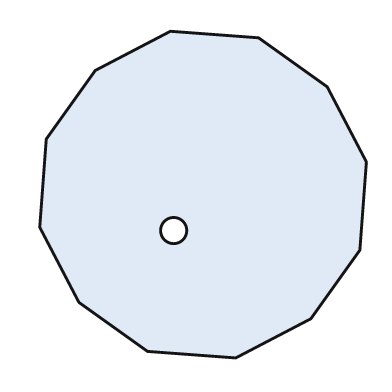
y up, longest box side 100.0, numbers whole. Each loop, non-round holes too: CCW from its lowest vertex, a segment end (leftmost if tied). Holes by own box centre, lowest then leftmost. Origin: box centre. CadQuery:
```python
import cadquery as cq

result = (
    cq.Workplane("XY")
    .moveTo(10.0, -50.0)
    .lineTo(33.0, -38.0)
    .lineTo(48.0, -17.0)
    .lineTo(50.0, 10.0)
    .lineTo(38.0, 33.0)
    .lineTo(17.0, 48.0)
    .lineTo(-10.0, 50.0)
    .lineTo(-33.0, 38.0)
    .lineTo(-48.0, 17.0)
    .lineTo(-50.0, -10.0)
    .lineTo(-38.0, -33.0)
    .lineTo(-17.0, -48.0)
    .close()
    .moveTo(-9.0, -11.0)
    .circle(4.0)
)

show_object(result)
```